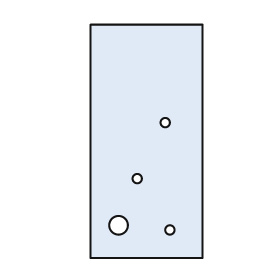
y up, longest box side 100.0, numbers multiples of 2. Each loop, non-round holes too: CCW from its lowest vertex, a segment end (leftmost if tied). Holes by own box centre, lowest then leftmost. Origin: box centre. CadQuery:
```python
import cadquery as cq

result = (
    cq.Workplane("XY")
    .moveTo(-24.0, -50.0)
    .lineTo(24.0, -50.0)
    .lineTo(24.0, 50.0)
    .lineTo(-24.0, 50.0)
    .close()
    .moveTo(10.0, -38.0)
    .circle(2.0)
    .moveTo(-12.0, -36.0)
    .circle(4.0)
    .moveTo(-4.0, -16.0)
    .circle(2.0)
    .moveTo(8.0, 8.0)
    .circle(2.0)
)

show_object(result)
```